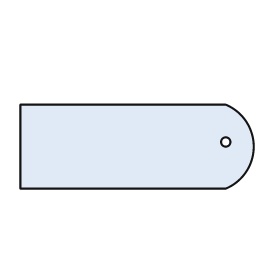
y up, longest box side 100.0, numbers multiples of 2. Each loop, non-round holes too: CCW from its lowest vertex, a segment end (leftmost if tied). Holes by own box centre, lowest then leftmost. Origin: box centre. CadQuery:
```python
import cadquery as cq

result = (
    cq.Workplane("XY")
    .moveTo(-50.0, -18.0)
    .lineTo(38.0, -18.0)
    .threePointArc((50.0, 0.0), (38.0, 18.0))
    .lineTo(-50.0, 18.0)
    .close()
    .moveTo(38.0, 2.0)
    .circle(2.0)
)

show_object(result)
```